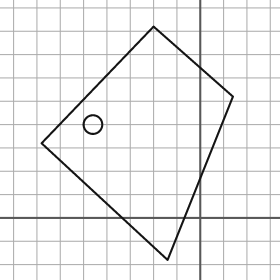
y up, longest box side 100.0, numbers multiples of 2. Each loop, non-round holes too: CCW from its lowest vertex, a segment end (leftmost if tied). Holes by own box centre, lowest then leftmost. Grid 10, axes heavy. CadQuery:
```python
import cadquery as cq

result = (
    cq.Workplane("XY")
    .moveTo(-14.0, -18.0)
    .lineTo(14.0, 52.0)
    .lineTo(-20.0, 82.0)
    .lineTo(-68.0, 32.0)
    .close()
    .moveTo(-46.0, 40.0)
    .circle(4.0)
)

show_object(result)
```